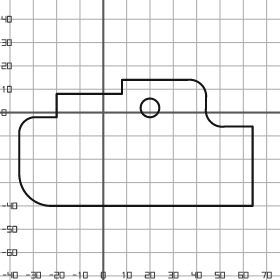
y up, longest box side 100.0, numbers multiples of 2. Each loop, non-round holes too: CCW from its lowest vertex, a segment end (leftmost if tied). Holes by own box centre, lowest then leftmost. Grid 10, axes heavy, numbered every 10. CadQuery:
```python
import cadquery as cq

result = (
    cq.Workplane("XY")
    .moveTo(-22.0, -40.0)
    .lineTo(64.0, -40.0)
    .lineTo(64.0, -6.0)
    .lineTo(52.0, -6.0)
    .threePointArc((46.0, -4.0), (44.0, 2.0))
    .lineTo(44.0, 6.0)
    .threePointArc((42.0, 12.0), (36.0, 14.0))
    .lineTo(8.0, 14.0)
    .lineTo(8.0, 8.0)
    .lineTo(-20.0, 8.0)
    .lineTo(-20.0, -2.0)
    .lineTo(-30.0, -2.0)
    .threePointArc((-34.0, -4.0), (-36.0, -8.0))
    .lineTo(-36.0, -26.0)
    .threePointArc((-32.0, -36.0), (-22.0, -40.0))
    .close()
    .moveTo(20.0, 2.0)
    .circle(4.0)
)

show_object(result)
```